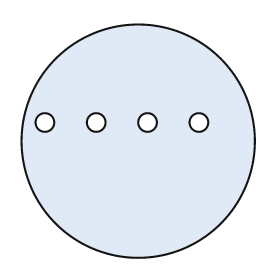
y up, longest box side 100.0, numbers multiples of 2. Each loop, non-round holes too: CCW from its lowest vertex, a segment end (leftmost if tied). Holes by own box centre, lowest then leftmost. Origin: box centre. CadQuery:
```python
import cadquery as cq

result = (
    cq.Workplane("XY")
    .moveTo(0.0, 0.0)
    .circle(50.0)
    .moveTo(-40.0, 8.0)
    .circle(4.0)
    .moveTo(-18.0, 8.0)
    .circle(4.0)
    .moveTo(4.0, 8.0)
    .circle(4.0)
    .moveTo(26.0, 8.0)
    .circle(4.0)
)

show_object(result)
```